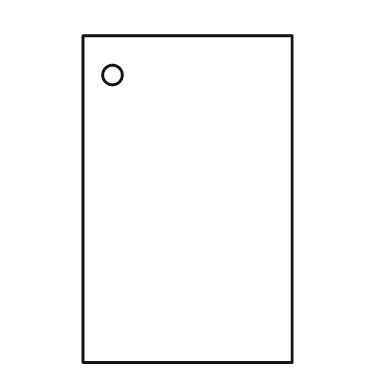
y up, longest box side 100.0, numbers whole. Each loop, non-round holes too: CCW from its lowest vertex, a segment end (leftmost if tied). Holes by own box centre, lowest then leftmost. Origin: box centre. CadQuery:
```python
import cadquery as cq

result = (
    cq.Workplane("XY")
    .moveTo(-32.0, -50.0)
    .lineTo(32.0, -50.0)
    .lineTo(32.0, 50.0)
    .lineTo(-32.0, 50.0)
    .close()
    .moveTo(-23.0, 38.0)
    .circle(3.0)
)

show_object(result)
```